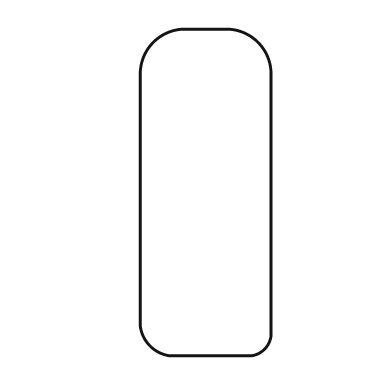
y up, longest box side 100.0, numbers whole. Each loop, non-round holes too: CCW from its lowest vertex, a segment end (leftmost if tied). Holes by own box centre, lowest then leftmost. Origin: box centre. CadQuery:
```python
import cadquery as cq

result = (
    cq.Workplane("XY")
    .moveTo(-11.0, -50.0)
    .lineTo(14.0, -50.0)
    .threePointArc((18.0, -48.0), (20.0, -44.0))
    .lineTo(20.0, 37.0)
    .threePointArc((16.0, 46.0), (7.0, 50.0))
    .lineTo(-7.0, 50.0)
    .threePointArc((-16.0, 46.0), (-20.0, 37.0))
    .lineTo(-20.0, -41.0)
    .threePointArc((-17.0, -47.0), (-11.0, -50.0))
    .close()
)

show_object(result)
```